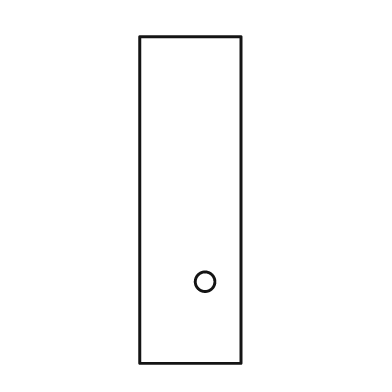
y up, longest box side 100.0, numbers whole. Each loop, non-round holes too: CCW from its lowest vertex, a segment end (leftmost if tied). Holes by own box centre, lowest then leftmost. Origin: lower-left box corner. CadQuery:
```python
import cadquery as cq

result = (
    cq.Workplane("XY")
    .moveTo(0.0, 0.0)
    .lineTo(31.0, 0.0)
    .lineTo(31.0, 100.0)
    .lineTo(0.0, 100.0)
    .close()
    .moveTo(20.0, 25.0)
    .circle(3.0)
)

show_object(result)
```